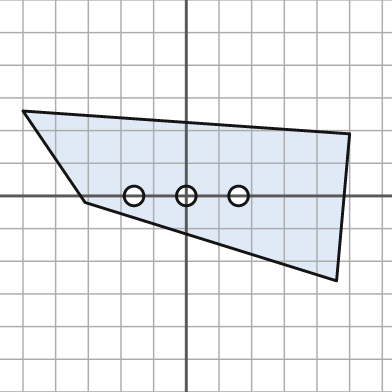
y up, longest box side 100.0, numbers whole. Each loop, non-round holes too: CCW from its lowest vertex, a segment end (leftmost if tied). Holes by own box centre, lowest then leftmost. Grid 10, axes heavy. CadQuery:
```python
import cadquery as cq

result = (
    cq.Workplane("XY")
    .moveTo(46.0, -26.0)
    .lineTo(50.0, 19.0)
    .lineTo(-50.0, 26.0)
    .lineTo(-31.0, -2.0)
    .close()
    .moveTo(-16.0, 0.0)
    .circle(3.0)
    .moveTo(0.0, 0.0)
    .circle(3.0)
    .moveTo(16.0, 0.0)
    .circle(3.0)
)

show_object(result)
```